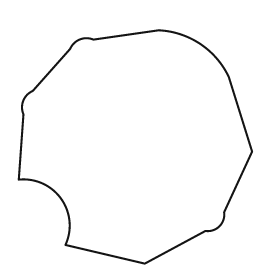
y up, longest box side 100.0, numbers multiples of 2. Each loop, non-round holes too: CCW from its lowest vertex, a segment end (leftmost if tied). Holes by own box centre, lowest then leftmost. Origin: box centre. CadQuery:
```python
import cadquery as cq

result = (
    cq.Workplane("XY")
    .moveTo(4.0, -50.0)
    .lineTo(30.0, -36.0)
    .threePointArc((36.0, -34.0), (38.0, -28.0))
    .lineTo(50.0, -2.0)
    .lineTo(40.0, 30.0)
    .threePointArc((28.0, 44.0), (10.0, 50.0))
    .lineTo(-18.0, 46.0)
    .threePointArc((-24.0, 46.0), (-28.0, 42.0))
    .lineTo(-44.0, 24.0)
    .threePointArc((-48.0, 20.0), (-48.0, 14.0))
    .lineTo(-50.0, -14.0)
    .threePointArc((-32.0, -22.0), (-30.0, -42.0))
    .close()
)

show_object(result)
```